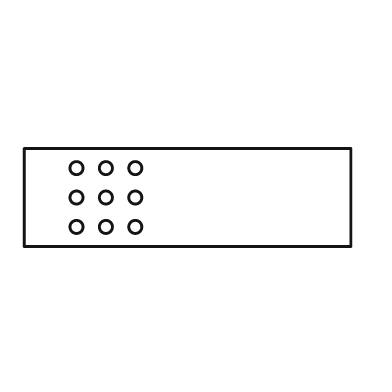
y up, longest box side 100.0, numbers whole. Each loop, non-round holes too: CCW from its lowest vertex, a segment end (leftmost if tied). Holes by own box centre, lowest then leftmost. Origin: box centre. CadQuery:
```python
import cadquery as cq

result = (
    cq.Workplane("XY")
    .moveTo(-50.0, -15.0)
    .lineTo(50.0, -15.0)
    .lineTo(50.0, 15.0)
    .lineTo(-50.0, 15.0)
    .close()
    .moveTo(-34.0, -9.0)
    .circle(2.0)
    .moveTo(-25.0, -9.0)
    .circle(2.0)
    .moveTo(-16.0, -9.0)
    .circle(2.0)
    .moveTo(-34.0, 0.0)
    .circle(2.0)
    .moveTo(-25.0, 0.0)
    .circle(2.0)
    .moveTo(-16.0, 0.0)
    .circle(2.0)
    .moveTo(-34.0, 9.0)
    .circle(2.0)
    .moveTo(-25.0, 9.0)
    .circle(2.0)
    .moveTo(-16.0, 9.0)
    .circle(2.0)
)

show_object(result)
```